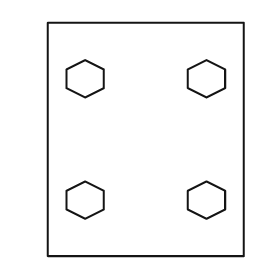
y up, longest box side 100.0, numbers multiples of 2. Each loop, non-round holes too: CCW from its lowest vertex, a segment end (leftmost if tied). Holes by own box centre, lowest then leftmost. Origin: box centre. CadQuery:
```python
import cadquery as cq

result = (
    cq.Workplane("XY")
    .moveTo(-42.0, -50.0)
    .lineTo(42.0, -50.0)
    .lineTo(42.0, 50.0)
    .lineTo(-42.0, 50.0)
    .close()
    .moveTo(-26.0, -34.0)
    .lineTo(-18.0, -30.0)
    .lineTo(-18.0, -22.0)
    .lineTo(-26.0, -18.0)
    .lineTo(-34.0, -22.0)
    .lineTo(-34.0, -30.0)
    .close()
    .moveTo(26.0, -34.0)
    .lineTo(34.0, -30.0)
    .lineTo(34.0, -22.0)
    .lineTo(26.0, -18.0)
    .lineTo(18.0, -22.0)
    .lineTo(18.0, -30.0)
    .close()
    .moveTo(-26.0, 18.0)
    .lineTo(-18.0, 22.0)
    .lineTo(-18.0, 30.0)
    .lineTo(-26.0, 34.0)
    .lineTo(-34.0, 30.0)
    .lineTo(-34.0, 22.0)
    .close()
    .moveTo(26.0, 18.0)
    .lineTo(34.0, 22.0)
    .lineTo(34.0, 30.0)
    .lineTo(26.0, 34.0)
    .lineTo(18.0, 30.0)
    .lineTo(18.0, 22.0)
    .close()
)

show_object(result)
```